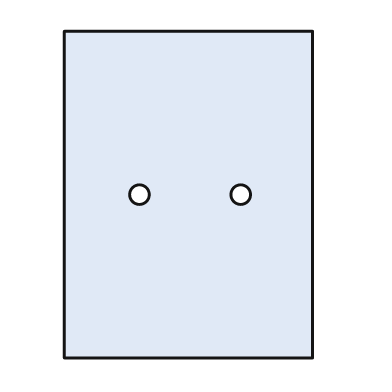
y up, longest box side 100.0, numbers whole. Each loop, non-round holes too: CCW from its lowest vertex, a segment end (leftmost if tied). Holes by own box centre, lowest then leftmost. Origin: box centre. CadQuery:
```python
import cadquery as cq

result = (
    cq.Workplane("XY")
    .moveTo(-38.0, -50.0)
    .lineTo(38.0, -50.0)
    .lineTo(38.0, 50.0)
    .lineTo(-38.0, 50.0)
    .close()
    .moveTo(-15.0, 0.0)
    .circle(3.0)
    .moveTo(16.0, 0.0)
    .circle(3.0)
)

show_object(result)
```